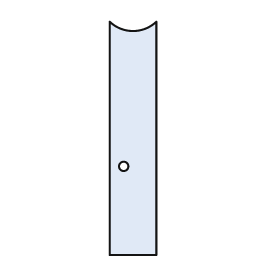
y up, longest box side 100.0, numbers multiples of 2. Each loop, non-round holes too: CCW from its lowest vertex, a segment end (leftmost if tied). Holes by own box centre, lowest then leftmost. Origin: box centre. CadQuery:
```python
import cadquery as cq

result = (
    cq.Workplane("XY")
    .moveTo(-10.0, -50.0)
    .lineTo(10.0, -50.0)
    .lineTo(10.0, 50.0)
    .threePointArc((0.0, 46.0), (-10.0, 50.0))
    .close()
    .moveTo(-4.0, -12.0)
    .circle(2.0)
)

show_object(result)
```